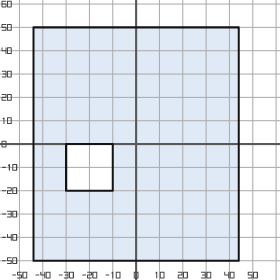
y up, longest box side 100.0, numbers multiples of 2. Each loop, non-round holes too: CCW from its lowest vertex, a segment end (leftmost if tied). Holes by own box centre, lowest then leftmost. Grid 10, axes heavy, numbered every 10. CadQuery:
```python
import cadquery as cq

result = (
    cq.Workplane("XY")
    .moveTo(-44.0, -50.0)
    .lineTo(44.0, -50.0)
    .lineTo(44.0, 50.0)
    .lineTo(-44.0, 50.0)
    .close()
    .moveTo(-30.0, -20.0)
    .lineTo(-10.0, -20.0)
    .lineTo(-10.0, 0.0)
    .lineTo(-30.0, 0.0)
    .close()
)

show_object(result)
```